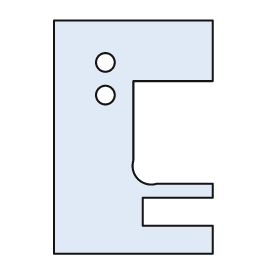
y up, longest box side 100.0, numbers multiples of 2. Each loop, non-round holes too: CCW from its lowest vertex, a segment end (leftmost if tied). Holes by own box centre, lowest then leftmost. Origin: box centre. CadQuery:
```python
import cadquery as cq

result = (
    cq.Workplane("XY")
    .moveTo(-34.0, -50.0)
    .lineTo(34.0, -50.0)
    .lineTo(34.0, -38.0)
    .lineTo(4.0, -38.0)
    .lineTo(4.0, -26.0)
    .lineTo(34.0, -26.0)
    .lineTo(34.0, -20.0)
    .lineTo(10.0, -20.0)
    .threePointArc((2.0, -18.0), (0.0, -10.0))
    .lineTo(0.0, 24.0)
    .lineTo(34.0, 24.0)
    .lineTo(34.0, 50.0)
    .lineTo(-34.0, 50.0)
    .close()
    .moveTo(-12.0, 18.0)
    .circle(4.0)
    .moveTo(-12.0, 32.0)
    .circle(4.0)
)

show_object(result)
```